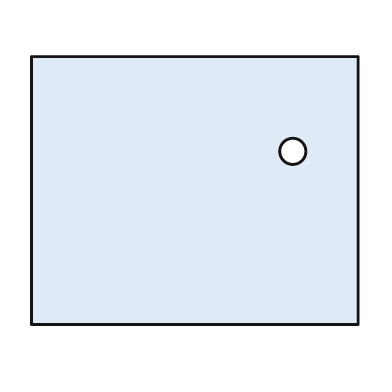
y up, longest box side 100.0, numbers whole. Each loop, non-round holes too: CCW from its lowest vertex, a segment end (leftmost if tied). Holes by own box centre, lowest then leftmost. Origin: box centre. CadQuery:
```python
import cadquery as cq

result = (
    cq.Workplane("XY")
    .moveTo(-50.0, -41.0)
    .lineTo(50.0, -41.0)
    .lineTo(50.0, 41.0)
    .lineTo(-50.0, 41.0)
    .close()
    .moveTo(30.0, 12.0)
    .circle(4.0)
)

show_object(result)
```